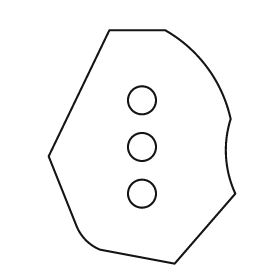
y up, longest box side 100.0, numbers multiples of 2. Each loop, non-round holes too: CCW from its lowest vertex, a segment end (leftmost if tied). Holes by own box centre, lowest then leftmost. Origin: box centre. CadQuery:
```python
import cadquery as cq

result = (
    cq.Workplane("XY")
    .moveTo(14.0, -50.0)
    .lineTo(40.0, -20.0)
    .threePointArc((36.0, -4.0), (38.0, 12.0))
    .threePointArc((28.0, 34.0), (10.0, 50.0))
    .lineTo(-14.0, 50.0)
    .lineTo(-40.0, -4.0)
    .lineTo(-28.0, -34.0)
    .threePointArc((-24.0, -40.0), (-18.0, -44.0))
    .close()
    .moveTo(0.0, -20.0)
    .circle(6.0)
    .moveTo(0.0, 0.0)
    .circle(6.0)
    .moveTo(0.0, 20.0)
    .circle(6.0)
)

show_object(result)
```